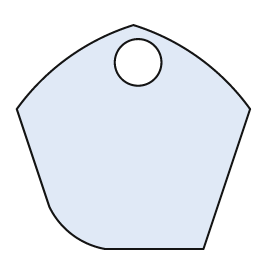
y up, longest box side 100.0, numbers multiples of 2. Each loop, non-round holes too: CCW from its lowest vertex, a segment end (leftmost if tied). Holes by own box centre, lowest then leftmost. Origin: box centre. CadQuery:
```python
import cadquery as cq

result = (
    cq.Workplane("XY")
    .moveTo(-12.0, -48.0)
    .lineTo(30.0, -48.0)
    .lineTo(50.0, 12.0)
    .threePointArc((28.0, 34.0), (0.0, 48.0))
    .threePointArc((-28.0, 34.0), (-50.0, 12.0))
    .lineTo(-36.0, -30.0)
    .threePointArc((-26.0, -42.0), (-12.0, -48.0))
    .close()
    .moveTo(2.0, 32.0)
    .circle(10.0)
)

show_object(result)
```